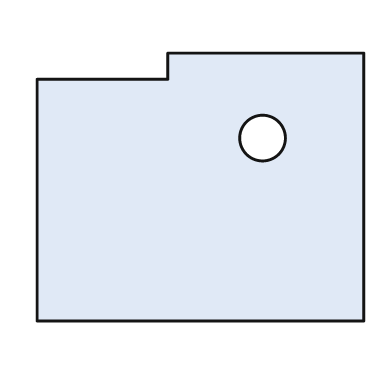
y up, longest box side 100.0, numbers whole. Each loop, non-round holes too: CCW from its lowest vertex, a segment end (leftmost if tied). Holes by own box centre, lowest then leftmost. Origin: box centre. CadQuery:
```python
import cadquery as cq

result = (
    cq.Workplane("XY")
    .moveTo(-50.0, -41.0)
    .lineTo(50.0, -41.0)
    .lineTo(50.0, 41.0)
    .lineTo(-10.0, 41.0)
    .lineTo(-10.0, 33.0)
    .lineTo(-50.0, 33.0)
    .close()
    .moveTo(19.0, 15.0)
    .circle(7.0)
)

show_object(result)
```